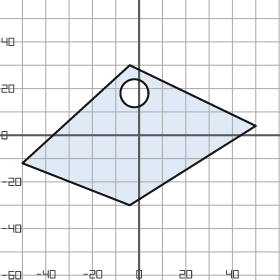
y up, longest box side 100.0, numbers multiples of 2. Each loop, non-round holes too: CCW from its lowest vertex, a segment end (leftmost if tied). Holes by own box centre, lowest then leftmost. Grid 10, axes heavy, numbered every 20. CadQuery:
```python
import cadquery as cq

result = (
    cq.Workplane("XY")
    .moveTo(-4.0, -30.0)
    .lineTo(50.0, 4.0)
    .lineTo(-4.0, 30.0)
    .lineTo(-50.0, -12.0)
    .close()
    .moveTo(-2.0, 18.0)
    .circle(6.0)
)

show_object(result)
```